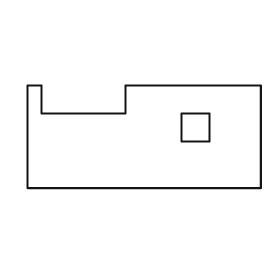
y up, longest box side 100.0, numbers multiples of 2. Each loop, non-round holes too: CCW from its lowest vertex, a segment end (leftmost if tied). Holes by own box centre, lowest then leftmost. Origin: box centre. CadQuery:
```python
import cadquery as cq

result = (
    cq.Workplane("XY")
    .moveTo(-50.0, -22.0)
    .lineTo(50.0, -22.0)
    .lineTo(50.0, 22.0)
    .lineTo(-8.0, 22.0)
    .lineTo(-8.0, 10.0)
    .lineTo(-44.0, 10.0)
    .lineTo(-44.0, 22.0)
    .lineTo(-50.0, 22.0)
    .close()
    .moveTo(16.0, -2.0)
    .lineTo(28.0, -2.0)
    .lineTo(28.0, 10.0)
    .lineTo(16.0, 10.0)
    .close()
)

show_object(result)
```